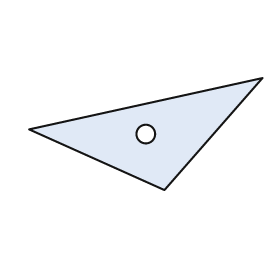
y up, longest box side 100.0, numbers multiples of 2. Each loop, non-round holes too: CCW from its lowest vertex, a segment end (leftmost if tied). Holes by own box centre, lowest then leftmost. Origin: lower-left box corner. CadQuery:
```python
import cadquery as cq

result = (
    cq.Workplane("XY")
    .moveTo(58.0, 0.0)
    .lineTo(100.0, 48.0)
    .lineTo(0.0, 26.0)
    .close()
    .moveTo(50.0, 24.0)
    .circle(4.0)
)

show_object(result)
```